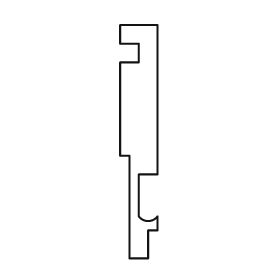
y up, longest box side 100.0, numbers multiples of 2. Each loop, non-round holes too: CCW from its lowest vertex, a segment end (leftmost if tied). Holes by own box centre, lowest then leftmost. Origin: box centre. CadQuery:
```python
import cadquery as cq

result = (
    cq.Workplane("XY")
    .moveTo(-4.0, -50.0)
    .lineTo(4.0, -50.0)
    .lineTo(4.0, -38.0)
    .lineTo(8.0, -38.0)
    .lineTo(8.0, -32.0)
    .threePointArc((4.0, -34.0), (0.0, -32.0))
    .lineTo(0.0, -14.0)
    .lineTo(8.0, -14.0)
    .lineTo(8.0, 50.0)
    .lineTo(-8.0, 50.0)
    .lineTo(-8.0, 42.0)
    .lineTo(0.0, 42.0)
    .lineTo(0.0, 34.0)
    .lineTo(-8.0, 34.0)
    .lineTo(-8.0, -6.0)
    .lineTo(-4.0, -6.0)
    .close()
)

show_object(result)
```